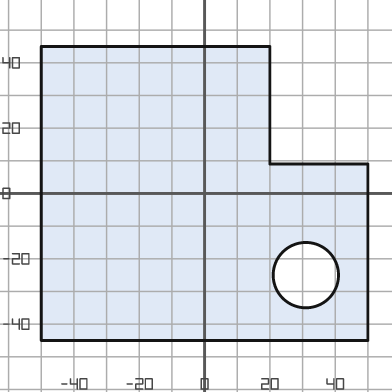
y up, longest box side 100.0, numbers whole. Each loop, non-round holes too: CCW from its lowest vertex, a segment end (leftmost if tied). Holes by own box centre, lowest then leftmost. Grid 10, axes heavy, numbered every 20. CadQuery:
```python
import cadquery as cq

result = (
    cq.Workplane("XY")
    .moveTo(-50.0, -45.0)
    .lineTo(50.0, -45.0)
    .lineTo(50.0, 9.0)
    .lineTo(20.0, 9.0)
    .lineTo(20.0, 45.0)
    .lineTo(-50.0, 45.0)
    .close()
    .moveTo(31.0, -25.0)
    .circle(10.0)
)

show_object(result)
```